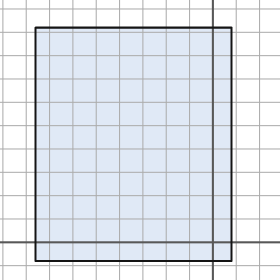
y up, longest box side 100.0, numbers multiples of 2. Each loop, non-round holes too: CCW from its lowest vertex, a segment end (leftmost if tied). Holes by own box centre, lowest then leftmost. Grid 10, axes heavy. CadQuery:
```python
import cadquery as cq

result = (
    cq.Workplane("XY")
    .moveTo(-76.0, -8.0)
    .lineTo(8.0, -8.0)
    .lineTo(8.0, 92.0)
    .lineTo(-76.0, 92.0)
    .close()
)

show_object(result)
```